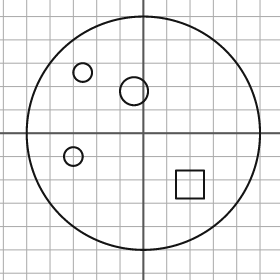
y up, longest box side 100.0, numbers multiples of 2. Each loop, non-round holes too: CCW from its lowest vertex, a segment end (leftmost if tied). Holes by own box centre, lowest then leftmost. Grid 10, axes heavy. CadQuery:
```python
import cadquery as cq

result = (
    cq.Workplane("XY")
    .moveTo(0.0, 0.0)
    .circle(50.0)
    .moveTo(14.0, -28.0)
    .lineTo(26.0, -28.0)
    .lineTo(26.0, -16.0)
    .lineTo(14.0, -16.0)
    .close()
    .moveTo(-30.0, -10.0)
    .circle(4.0)
    .moveTo(-4.0, 18.0)
    .circle(6.0)
    .moveTo(-26.0, 26.0)
    .circle(4.0)
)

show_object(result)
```